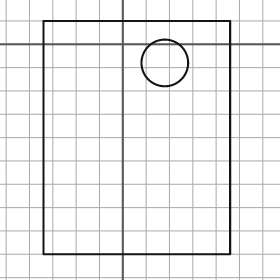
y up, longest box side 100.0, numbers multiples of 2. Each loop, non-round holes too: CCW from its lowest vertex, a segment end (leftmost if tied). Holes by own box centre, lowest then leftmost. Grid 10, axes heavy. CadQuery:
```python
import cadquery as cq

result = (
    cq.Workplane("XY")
    .moveTo(-34.0, -90.0)
    .lineTo(46.0, -90.0)
    .lineTo(46.0, 10.0)
    .lineTo(-34.0, 10.0)
    .close()
    .moveTo(18.0, -8.0)
    .circle(10.0)
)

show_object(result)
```